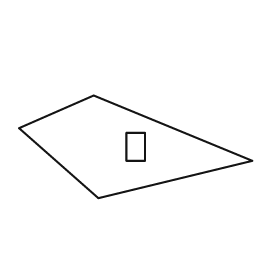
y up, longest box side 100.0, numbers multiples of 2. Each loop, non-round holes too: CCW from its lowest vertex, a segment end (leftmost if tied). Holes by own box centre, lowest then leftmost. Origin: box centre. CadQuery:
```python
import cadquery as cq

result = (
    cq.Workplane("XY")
    .moveTo(-16.0, -22.0)
    .lineTo(50.0, -6.0)
    .lineTo(-18.0, 22.0)
    .lineTo(-50.0, 8.0)
    .close()
    .moveTo(-4.0, -6.0)
    .lineTo(4.0, -6.0)
    .lineTo(4.0, 6.0)
    .lineTo(-4.0, 6.0)
    .close()
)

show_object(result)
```